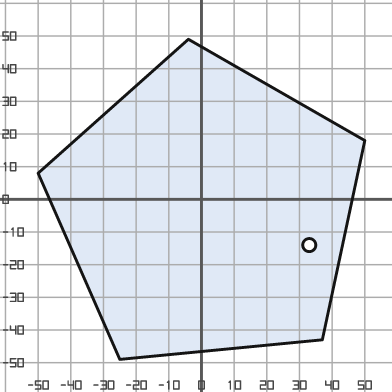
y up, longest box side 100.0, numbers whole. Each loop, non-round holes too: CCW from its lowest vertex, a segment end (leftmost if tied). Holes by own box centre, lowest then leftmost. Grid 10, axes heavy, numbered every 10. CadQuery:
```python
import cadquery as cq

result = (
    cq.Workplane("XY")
    .moveTo(-25.0, -49.0)
    .lineTo(37.0, -43.0)
    .lineTo(50.0, 18.0)
    .lineTo(-4.0, 49.0)
    .lineTo(-50.0, 8.0)
    .close()
    .moveTo(33.0, -14.0)
    .circle(2.0)
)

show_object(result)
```